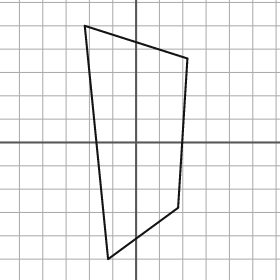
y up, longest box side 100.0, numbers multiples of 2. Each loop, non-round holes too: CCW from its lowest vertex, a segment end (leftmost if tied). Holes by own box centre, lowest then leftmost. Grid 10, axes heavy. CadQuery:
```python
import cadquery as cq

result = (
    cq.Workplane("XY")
    .moveTo(-12.0, -50.0)
    .lineTo(18.0, -28.0)
    .lineTo(22.0, 36.0)
    .lineTo(-22.0, 50.0)
    .close()
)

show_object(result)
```